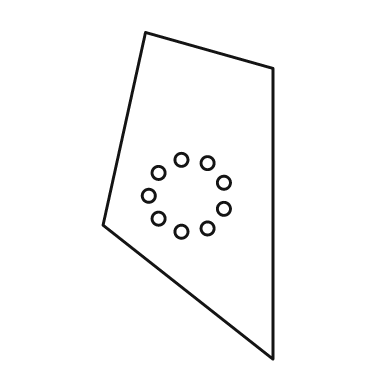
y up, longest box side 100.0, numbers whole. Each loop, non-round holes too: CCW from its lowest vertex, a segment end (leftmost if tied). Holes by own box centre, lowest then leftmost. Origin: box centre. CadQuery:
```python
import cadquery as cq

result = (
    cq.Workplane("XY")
    .moveTo(26.0, -50.0)
    .lineTo(26.0, 39.0)
    .lineTo(-13.0, 50.0)
    .lineTo(-26.0, -9.0)
    .close()
    .moveTo(-2.0, -11.0)
    .circle(2.0)
    .moveTo(6.0, -10.0)
    .circle(2.0)
    .moveTo(-9.0, -7.0)
    .circle(2.0)
    .moveTo(11.0, -4.0)
    .circle(2.0)
    .moveTo(-12.0, 0.0)
    .circle(2.0)
    .moveTo(11.0, 4.0)
    .circle(2.0)
    .moveTo(-9.0, 7.0)
    .circle(2.0)
    .moveTo(6.0, 10.0)
    .circle(2.0)
    .moveTo(-2.0, 11.0)
    .circle(2.0)
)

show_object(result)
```